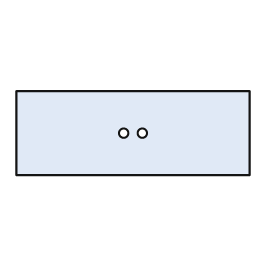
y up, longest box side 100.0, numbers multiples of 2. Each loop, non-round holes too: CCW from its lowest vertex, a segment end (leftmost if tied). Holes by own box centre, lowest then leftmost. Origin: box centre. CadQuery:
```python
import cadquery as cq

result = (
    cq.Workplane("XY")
    .moveTo(-50.0, -18.0)
    .lineTo(50.0, -18.0)
    .lineTo(50.0, 18.0)
    .lineTo(-50.0, 18.0)
    .close()
    .moveTo(-4.0, 0.0)
    .circle(2.0)
    .moveTo(4.0, 0.0)
    .circle(2.0)
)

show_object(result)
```